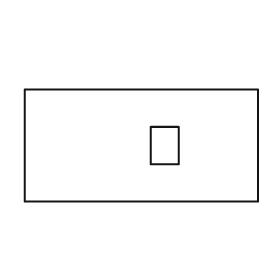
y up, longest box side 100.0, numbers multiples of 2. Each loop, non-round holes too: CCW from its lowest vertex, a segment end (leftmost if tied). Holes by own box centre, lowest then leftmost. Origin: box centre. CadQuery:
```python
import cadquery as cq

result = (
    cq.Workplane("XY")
    .moveTo(-50.0, -24.0)
    .lineTo(50.0, -24.0)
    .lineTo(50.0, 24.0)
    .lineTo(-50.0, 24.0)
    .close()
    .moveTo(4.0, -8.0)
    .lineTo(16.0, -8.0)
    .lineTo(16.0, 8.0)
    .lineTo(4.0, 8.0)
    .close()
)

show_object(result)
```